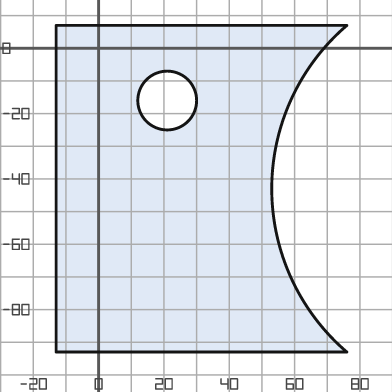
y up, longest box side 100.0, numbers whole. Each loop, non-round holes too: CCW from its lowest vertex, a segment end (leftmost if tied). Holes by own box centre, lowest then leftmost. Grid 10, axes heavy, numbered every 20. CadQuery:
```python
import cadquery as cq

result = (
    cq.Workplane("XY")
    .moveTo(-13.0, -93.0)
    .lineTo(76.0, -93.0)
    .threePointArc((53.0, -43.0), (76.0, 7.0))
    .lineTo(-13.0, 7.0)
    .close()
    .moveTo(21.0, -16.0)
    .circle(9.0)
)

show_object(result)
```